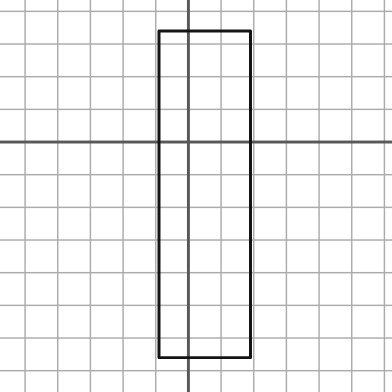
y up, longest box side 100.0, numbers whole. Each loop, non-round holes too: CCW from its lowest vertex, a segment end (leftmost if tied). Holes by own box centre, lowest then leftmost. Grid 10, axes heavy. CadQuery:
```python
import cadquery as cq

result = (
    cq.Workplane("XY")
    .moveTo(-9.0, -66.0)
    .lineTo(19.0, -66.0)
    .lineTo(19.0, 34.0)
    .lineTo(-9.0, 34.0)
    .close()
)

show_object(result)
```